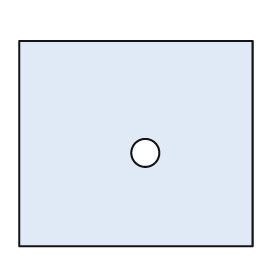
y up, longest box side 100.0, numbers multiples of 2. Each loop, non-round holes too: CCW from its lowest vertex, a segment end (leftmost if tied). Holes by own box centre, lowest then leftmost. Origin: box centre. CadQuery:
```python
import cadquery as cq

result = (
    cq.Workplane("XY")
    .moveTo(-50.0, -44.0)
    .lineTo(50.0, -44.0)
    .lineTo(50.0, 44.0)
    .lineTo(-50.0, 44.0)
    .close()
    .moveTo(4.0, -4.0)
    .circle(6.0)
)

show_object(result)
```